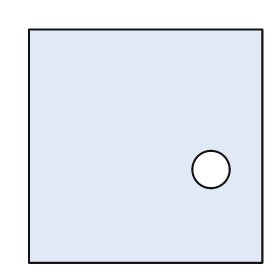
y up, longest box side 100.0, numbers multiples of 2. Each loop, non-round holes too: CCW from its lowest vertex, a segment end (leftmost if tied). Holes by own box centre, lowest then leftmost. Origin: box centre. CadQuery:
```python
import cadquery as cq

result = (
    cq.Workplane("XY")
    .moveTo(-50.0, -50.0)
    .lineTo(50.0, -50.0)
    .lineTo(50.0, 50.0)
    .lineTo(-50.0, 50.0)
    .close()
    .moveTo(28.0, -10.0)
    .circle(8.0)
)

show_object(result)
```